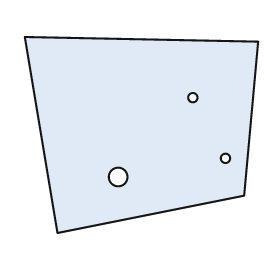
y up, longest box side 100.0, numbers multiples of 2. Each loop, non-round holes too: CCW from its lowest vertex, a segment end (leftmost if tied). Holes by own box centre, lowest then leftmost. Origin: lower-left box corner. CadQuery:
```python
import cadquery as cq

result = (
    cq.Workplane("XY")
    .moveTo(14.0, 0.0)
    .lineTo(94.0, 16.0)
    .lineTo(100.0, 82.0)
    .lineTo(0.0, 84.0)
    .close()
    .moveTo(40.0, 24.0)
    .circle(4.0)
    .moveTo(86.0, 32.0)
    .circle(2.0)
    .moveTo(72.0, 58.0)
    .circle(2.0)
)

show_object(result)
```